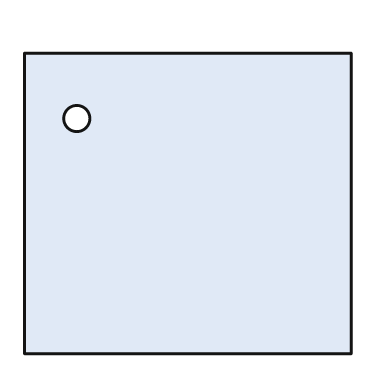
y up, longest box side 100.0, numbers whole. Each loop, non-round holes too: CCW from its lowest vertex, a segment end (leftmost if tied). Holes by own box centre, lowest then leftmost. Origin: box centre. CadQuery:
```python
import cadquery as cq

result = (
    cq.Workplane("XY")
    .moveTo(-50.0, -46.0)
    .lineTo(50.0, -46.0)
    .lineTo(50.0, 46.0)
    .lineTo(-50.0, 46.0)
    .close()
    .moveTo(-34.0, 26.0)
    .circle(4.0)
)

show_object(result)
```